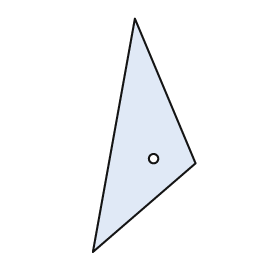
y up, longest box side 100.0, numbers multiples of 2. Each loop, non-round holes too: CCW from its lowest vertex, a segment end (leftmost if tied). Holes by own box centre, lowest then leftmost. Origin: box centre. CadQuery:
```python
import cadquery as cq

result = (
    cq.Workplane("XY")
    .moveTo(-22.0, -50.0)
    .lineTo(22.0, -12.0)
    .lineTo(-4.0, 50.0)
    .close()
    .moveTo(4.0, -10.0)
    .circle(2.0)
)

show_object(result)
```